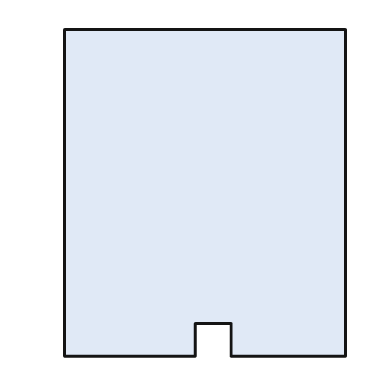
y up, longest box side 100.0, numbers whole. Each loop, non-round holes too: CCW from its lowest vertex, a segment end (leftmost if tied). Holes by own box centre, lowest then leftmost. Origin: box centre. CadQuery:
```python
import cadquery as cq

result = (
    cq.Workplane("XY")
    .moveTo(-43.0, -50.0)
    .lineTo(-3.0, -50.0)
    .lineTo(-3.0, -40.0)
    .lineTo(8.0, -40.0)
    .lineTo(8.0, -50.0)
    .lineTo(43.0, -50.0)
    .lineTo(43.0, 50.0)
    .lineTo(-43.0, 50.0)
    .close()
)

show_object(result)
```